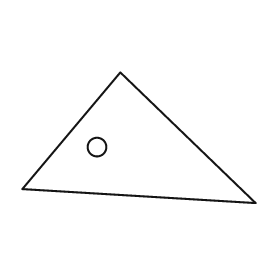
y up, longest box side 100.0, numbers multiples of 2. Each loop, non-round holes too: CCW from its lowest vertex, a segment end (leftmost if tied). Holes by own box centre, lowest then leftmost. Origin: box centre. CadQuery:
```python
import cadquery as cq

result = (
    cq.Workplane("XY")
    .moveTo(50.0, -28.0)
    .lineTo(-8.0, 28.0)
    .lineTo(-50.0, -22.0)
    .close()
    .moveTo(-18.0, -4.0)
    .circle(4.0)
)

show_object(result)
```